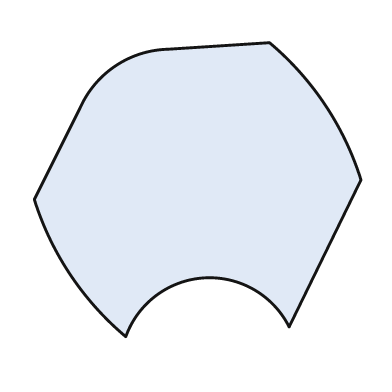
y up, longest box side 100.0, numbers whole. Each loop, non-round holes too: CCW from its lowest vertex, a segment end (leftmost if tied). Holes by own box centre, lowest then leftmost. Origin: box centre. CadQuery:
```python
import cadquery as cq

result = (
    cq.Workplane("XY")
    .moveTo(-22.0, -45.0)
    .threePointArc((2.0, -27.0), (28.0, -42.0))
    .lineTo(50.0, 3.0)
    .threePointArc((39.0, 26.0), (22.0, 45.0))
    .lineTo(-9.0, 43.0)
    .threePointArc((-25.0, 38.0), (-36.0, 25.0))
    .lineTo(-50.0, -3.0)
    .threePointArc((-39.0, -26.0), (-22.0, -45.0))
    .close()
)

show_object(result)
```